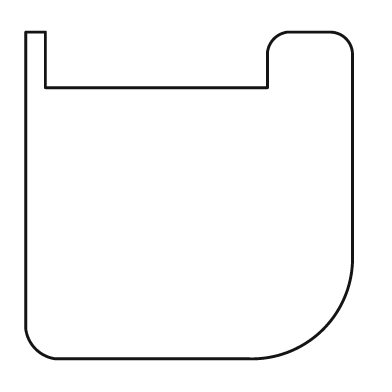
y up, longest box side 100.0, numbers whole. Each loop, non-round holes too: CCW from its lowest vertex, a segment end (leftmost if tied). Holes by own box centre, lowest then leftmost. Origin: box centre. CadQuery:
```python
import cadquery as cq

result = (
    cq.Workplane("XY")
    .moveTo(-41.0, -50.0)
    .lineTo(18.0, -50.0)
    .threePointArc((41.0, -41.0), (50.0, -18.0))
    .lineTo(50.0, 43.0)
    .threePointArc((48.0, 48.0), (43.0, 50.0))
    .lineTo(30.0, 50.0)
    .threePointArc((26.0, 48.0), (24.0, 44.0))
    .lineTo(24.0, 33.0)
    .lineTo(-44.0, 33.0)
    .lineTo(-44.0, 50.0)
    .lineTo(-50.0, 50.0)
    .lineTo(-50.0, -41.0)
    .threePointArc((-47.0, -47.0), (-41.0, -50.0))
    .close()
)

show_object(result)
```